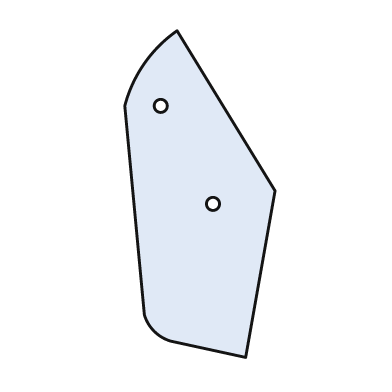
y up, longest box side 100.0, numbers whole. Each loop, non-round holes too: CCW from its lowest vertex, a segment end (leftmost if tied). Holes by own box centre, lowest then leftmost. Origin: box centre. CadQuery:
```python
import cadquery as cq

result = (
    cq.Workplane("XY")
    .moveTo(14.0, -50.0)
    .lineTo(23.0, 1.0)
    .lineTo(-7.0, 50.0)
    .threePointArc((-17.0, 40.0), (-23.0, 27.0))
    .lineTo(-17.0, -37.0)
    .threePointArc((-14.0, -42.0), (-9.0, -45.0))
    .close()
    .moveTo(4.0, -3.0)
    .circle(2.0)
    .moveTo(-12.0, 27.0)
    .circle(2.0)
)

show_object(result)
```